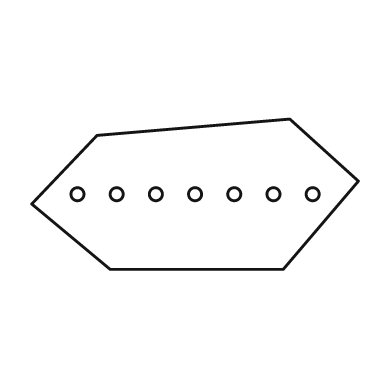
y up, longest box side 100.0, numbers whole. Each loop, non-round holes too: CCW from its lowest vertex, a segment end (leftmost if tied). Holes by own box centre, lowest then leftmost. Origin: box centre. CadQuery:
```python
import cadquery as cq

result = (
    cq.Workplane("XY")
    .moveTo(-26.0, -23.0)
    .lineTo(27.0, -23.0)
    .lineTo(50.0, 4.0)
    .lineTo(29.0, 23.0)
    .lineTo(-30.0, 18.0)
    .lineTo(-50.0, -3.0)
    .close()
    .moveTo(-36.0, 0.0)
    .circle(2.0)
    .moveTo(-24.0, 0.0)
    .circle(2.0)
    .moveTo(-12.0, 0.0)
    .circle(2.0)
    .moveTo(0.0, 0.0)
    .circle(2.0)
    .moveTo(12.0, 0.0)
    .circle(2.0)
    .moveTo(24.0, 0.0)
    .circle(2.0)
    .moveTo(36.0, 0.0)
    .circle(2.0)
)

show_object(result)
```